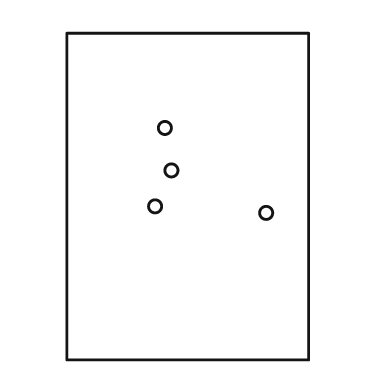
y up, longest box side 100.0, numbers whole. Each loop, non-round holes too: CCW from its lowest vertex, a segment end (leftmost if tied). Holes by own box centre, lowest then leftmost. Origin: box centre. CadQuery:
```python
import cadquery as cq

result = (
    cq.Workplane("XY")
    .moveTo(-37.0, -50.0)
    .lineTo(37.0, -50.0)
    .lineTo(37.0, 50.0)
    .lineTo(-37.0, 50.0)
    .close()
    .moveTo(24.0, -5.0)
    .circle(2.0)
    .moveTo(-10.0, -3.0)
    .circle(2.0)
    .moveTo(-5.0, 8.0)
    .circle(2.0)
    .moveTo(-7.0, 21.0)
    .circle(2.0)
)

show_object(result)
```